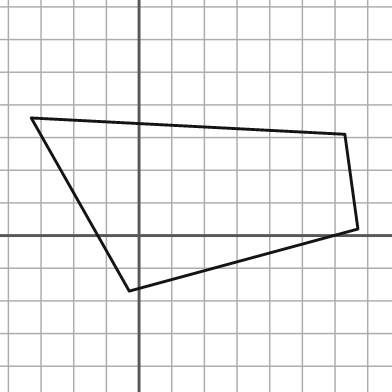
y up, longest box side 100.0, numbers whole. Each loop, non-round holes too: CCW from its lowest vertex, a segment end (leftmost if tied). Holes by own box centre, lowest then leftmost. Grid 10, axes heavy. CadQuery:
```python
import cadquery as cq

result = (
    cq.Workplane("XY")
    .moveTo(-3.0, -17.0)
    .lineTo(67.0, 2.0)
    .lineTo(63.0, 31.0)
    .lineTo(-33.0, 36.0)
    .close()
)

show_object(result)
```